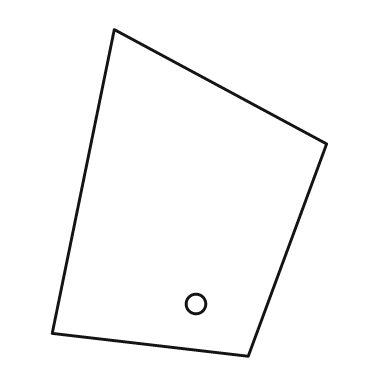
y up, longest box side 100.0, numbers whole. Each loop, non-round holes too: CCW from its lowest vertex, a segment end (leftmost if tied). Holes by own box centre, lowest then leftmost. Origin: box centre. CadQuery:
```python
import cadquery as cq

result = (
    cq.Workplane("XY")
    .moveTo(18.0, -50.0)
    .lineTo(42.0, 15.0)
    .lineTo(-23.0, 50.0)
    .lineTo(-42.0, -43.0)
    .close()
    .moveTo(2.0, -34.0)
    .circle(3.0)
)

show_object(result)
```